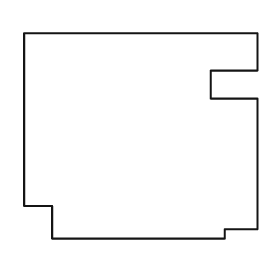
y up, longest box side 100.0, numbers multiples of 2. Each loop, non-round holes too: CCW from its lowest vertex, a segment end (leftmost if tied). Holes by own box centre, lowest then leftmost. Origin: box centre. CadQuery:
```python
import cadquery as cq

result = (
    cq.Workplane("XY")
    .moveTo(-38.0, -44.0)
    .lineTo(36.0, -44.0)
    .lineTo(36.0, -40.0)
    .lineTo(50.0, -40.0)
    .lineTo(50.0, 16.0)
    .lineTo(30.0, 16.0)
    .lineTo(30.0, 28.0)
    .lineTo(50.0, 28.0)
    .lineTo(50.0, 44.0)
    .lineTo(-50.0, 44.0)
    .lineTo(-50.0, -30.0)
    .lineTo(-38.0, -30.0)
    .close()
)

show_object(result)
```